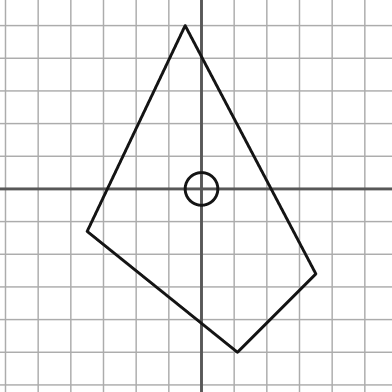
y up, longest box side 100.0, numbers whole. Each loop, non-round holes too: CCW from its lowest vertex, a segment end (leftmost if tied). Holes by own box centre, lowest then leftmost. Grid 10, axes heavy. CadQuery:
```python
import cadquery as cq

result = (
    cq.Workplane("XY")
    .moveTo(11.0, -50.0)
    .lineTo(35.0, -26.0)
    .lineTo(-5.0, 50.0)
    .lineTo(-35.0, -13.0)
    .close()
    .moveTo(0.0, 0.0)
    .circle(5.0)
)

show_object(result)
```